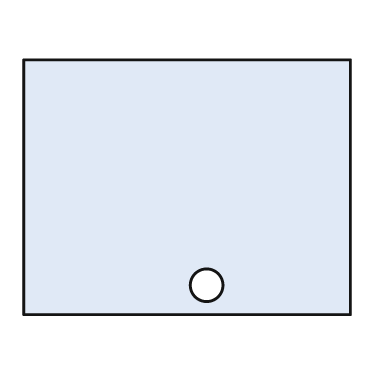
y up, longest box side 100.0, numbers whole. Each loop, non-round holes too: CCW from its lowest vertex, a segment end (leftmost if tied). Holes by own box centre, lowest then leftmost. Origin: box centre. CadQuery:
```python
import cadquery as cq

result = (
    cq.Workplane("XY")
    .moveTo(-50.0, -39.0)
    .lineTo(50.0, -39.0)
    .lineTo(50.0, 39.0)
    .lineTo(-50.0, 39.0)
    .close()
    .moveTo(6.0, -30.0)
    .circle(5.0)
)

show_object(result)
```